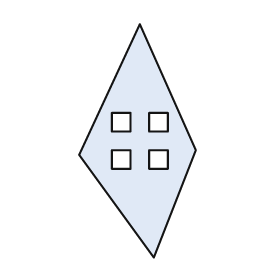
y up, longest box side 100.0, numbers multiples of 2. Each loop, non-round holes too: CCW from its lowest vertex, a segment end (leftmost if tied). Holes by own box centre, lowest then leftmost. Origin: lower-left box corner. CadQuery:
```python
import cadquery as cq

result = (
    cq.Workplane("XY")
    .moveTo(32.0, 0.0)
    .lineTo(50.0, 46.0)
    .lineTo(26.0, 100.0)
    .lineTo(0.0, 44.0)
    .close()
    .moveTo(14.0, 38.0)
    .lineTo(22.0, 38.0)
    .lineTo(22.0, 46.0)
    .lineTo(14.0, 46.0)
    .close()
    .moveTo(30.0, 38.0)
    .lineTo(38.0, 38.0)
    .lineTo(38.0, 46.0)
    .lineTo(30.0, 46.0)
    .close()
    .moveTo(14.0, 54.0)
    .lineTo(22.0, 54.0)
    .lineTo(22.0, 62.0)
    .lineTo(14.0, 62.0)
    .close()
    .moveTo(30.0, 54.0)
    .lineTo(38.0, 54.0)
    .lineTo(38.0, 62.0)
    .lineTo(30.0, 62.0)
    .close()
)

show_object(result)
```